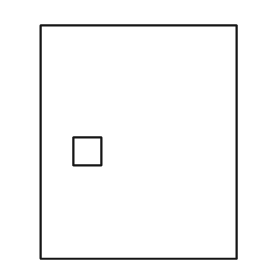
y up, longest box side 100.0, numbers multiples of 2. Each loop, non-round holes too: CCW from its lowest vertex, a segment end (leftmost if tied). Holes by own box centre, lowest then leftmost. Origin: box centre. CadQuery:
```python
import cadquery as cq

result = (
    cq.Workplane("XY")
    .moveTo(-42.0, -50.0)
    .lineTo(42.0, -50.0)
    .lineTo(42.0, 50.0)
    .lineTo(-42.0, 50.0)
    .close()
    .moveTo(-28.0, -10.0)
    .lineTo(-16.0, -10.0)
    .lineTo(-16.0, 2.0)
    .lineTo(-28.0, 2.0)
    .close()
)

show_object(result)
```